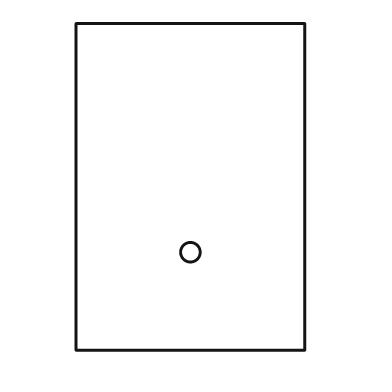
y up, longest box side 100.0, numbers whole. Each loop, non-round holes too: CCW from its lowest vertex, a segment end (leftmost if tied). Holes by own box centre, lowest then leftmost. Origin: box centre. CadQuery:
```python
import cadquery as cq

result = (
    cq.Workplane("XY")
    .moveTo(-35.0, -50.0)
    .lineTo(35.0, -50.0)
    .lineTo(35.0, 50.0)
    .lineTo(-35.0, 50.0)
    .close()
    .moveTo(0.0, -20.0)
    .circle(3.0)
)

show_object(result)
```